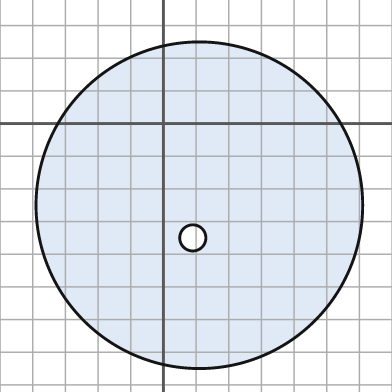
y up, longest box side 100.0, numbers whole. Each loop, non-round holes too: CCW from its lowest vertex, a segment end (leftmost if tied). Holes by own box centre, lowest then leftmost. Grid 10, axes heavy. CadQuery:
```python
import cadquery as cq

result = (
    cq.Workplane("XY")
    .moveTo(11.0, -25.0)
    .circle(50.0)
    .moveTo(9.0, -35.0)
    .circle(4.0)
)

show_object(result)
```